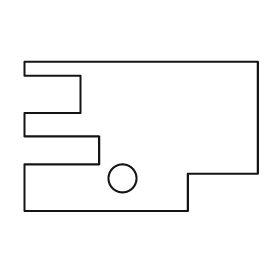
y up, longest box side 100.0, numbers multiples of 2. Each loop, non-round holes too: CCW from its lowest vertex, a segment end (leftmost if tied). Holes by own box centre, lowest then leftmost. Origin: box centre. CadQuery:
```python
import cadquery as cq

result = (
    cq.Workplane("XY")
    .moveTo(-50.0, -32.0)
    .lineTo(20.0, -32.0)
    .lineTo(20.0, -16.0)
    .lineTo(50.0, -16.0)
    .lineTo(50.0, 32.0)
    .lineTo(-50.0, 32.0)
    .lineTo(-50.0, 26.0)
    .lineTo(-26.0, 26.0)
    .lineTo(-26.0, 10.0)
    .lineTo(-50.0, 10.0)
    .lineTo(-50.0, 0.0)
    .lineTo(-18.0, 0.0)
    .lineTo(-18.0, -12.0)
    .lineTo(-50.0, -12.0)
    .close()
    .moveTo(-8.0, -18.0)
    .circle(6.0)
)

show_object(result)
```